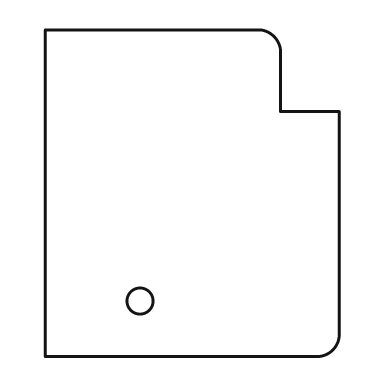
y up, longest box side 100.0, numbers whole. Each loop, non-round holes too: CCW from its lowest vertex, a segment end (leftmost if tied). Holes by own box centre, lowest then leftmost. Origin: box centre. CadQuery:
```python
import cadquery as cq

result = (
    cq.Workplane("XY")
    .moveTo(-45.0, -50.0)
    .lineTo(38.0, -50.0)
    .threePointArc((43.0, -48.0), (45.0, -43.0))
    .lineTo(45.0, 25.0)
    .lineTo(27.0, 25.0)
    .lineTo(27.0, 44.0)
    .threePointArc((25.0, 48.0), (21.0, 50.0))
    .lineTo(-45.0, 50.0)
    .close()
    .moveTo(-16.0, -33.0)
    .circle(4.0)
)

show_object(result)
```